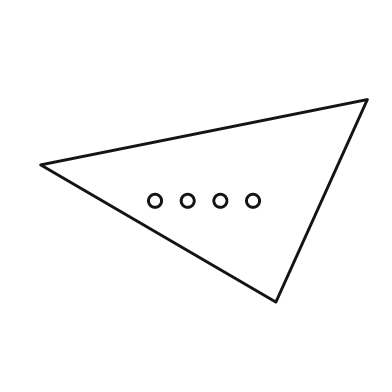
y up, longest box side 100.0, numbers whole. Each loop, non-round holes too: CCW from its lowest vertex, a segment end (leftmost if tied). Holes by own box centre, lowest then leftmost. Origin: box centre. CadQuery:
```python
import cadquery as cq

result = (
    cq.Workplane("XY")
    .moveTo(22.0, -31.0)
    .lineTo(50.0, 31.0)
    .lineTo(-50.0, 11.0)
    .close()
    .moveTo(-15.0, 0.0)
    .circle(2.0)
    .moveTo(-5.0, 0.0)
    .circle(2.0)
    .moveTo(5.0, 0.0)
    .circle(2.0)
    .moveTo(15.0, 0.0)
    .circle(2.0)
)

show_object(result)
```